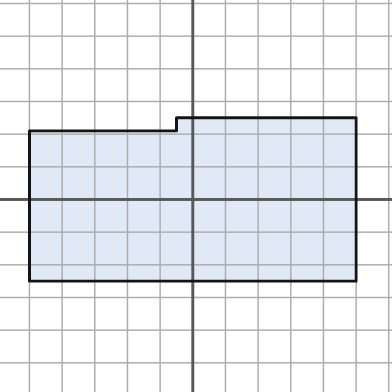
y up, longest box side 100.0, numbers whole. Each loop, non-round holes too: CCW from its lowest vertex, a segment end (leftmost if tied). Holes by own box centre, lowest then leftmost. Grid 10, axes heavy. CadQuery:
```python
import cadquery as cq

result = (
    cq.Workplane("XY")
    .moveTo(-50.0, -25.0)
    .lineTo(50.0, -25.0)
    .lineTo(50.0, 25.0)
    .lineTo(-5.0, 25.0)
    .lineTo(-5.0, 21.0)
    .lineTo(-50.0, 21.0)
    .close()
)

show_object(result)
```